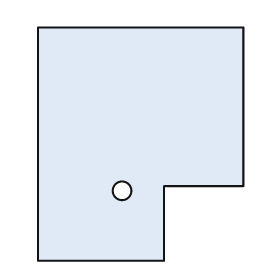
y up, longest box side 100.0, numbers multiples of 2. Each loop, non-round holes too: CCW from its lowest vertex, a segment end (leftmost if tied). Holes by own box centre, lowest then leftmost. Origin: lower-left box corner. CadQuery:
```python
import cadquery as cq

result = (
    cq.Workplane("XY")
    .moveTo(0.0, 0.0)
    .lineTo(54.0, 0.0)
    .lineTo(54.0, 32.0)
    .lineTo(88.0, 32.0)
    .lineTo(88.0, 100.0)
    .lineTo(0.0, 100.0)
    .close()
    .moveTo(36.0, 30.0)
    .circle(4.0)
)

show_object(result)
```